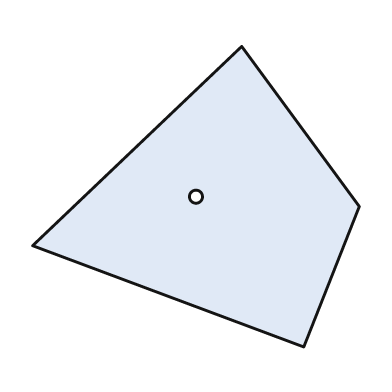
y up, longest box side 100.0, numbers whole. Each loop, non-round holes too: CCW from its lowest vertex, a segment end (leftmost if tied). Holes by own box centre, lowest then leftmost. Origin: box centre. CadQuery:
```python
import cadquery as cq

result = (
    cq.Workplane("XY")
    .moveTo(33.0, -46.0)
    .lineTo(50.0, -3.0)
    .lineTo(14.0, 46.0)
    .lineTo(-50.0, -15.0)
    .close()
    .moveTo(0.0, 0.0)
    .circle(2.0)
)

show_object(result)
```